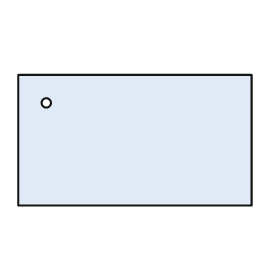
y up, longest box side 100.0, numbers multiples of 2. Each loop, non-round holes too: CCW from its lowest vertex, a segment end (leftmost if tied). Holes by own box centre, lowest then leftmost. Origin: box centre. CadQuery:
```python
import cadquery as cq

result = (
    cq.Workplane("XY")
    .moveTo(-50.0, -28.0)
    .lineTo(50.0, -28.0)
    .lineTo(50.0, 28.0)
    .lineTo(-50.0, 28.0)
    .close()
    .moveTo(-38.0, 16.0)
    .circle(2.0)
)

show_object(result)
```